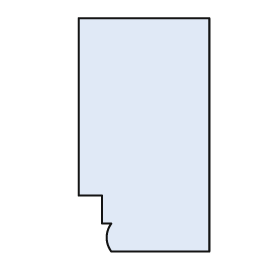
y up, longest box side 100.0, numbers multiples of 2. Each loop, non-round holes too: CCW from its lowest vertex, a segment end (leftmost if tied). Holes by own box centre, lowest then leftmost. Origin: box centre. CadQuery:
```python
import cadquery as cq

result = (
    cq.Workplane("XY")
    .moveTo(-14.0, -50.0)
    .lineTo(28.0, -50.0)
    .lineTo(28.0, 50.0)
    .lineTo(-28.0, 50.0)
    .lineTo(-28.0, -26.0)
    .lineTo(-18.0, -26.0)
    .lineTo(-18.0, -38.0)
    .lineTo(-14.0, -38.0)
    .threePointArc((-16.0, -44.0), (-14.0, -50.0))
    .close()
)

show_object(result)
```